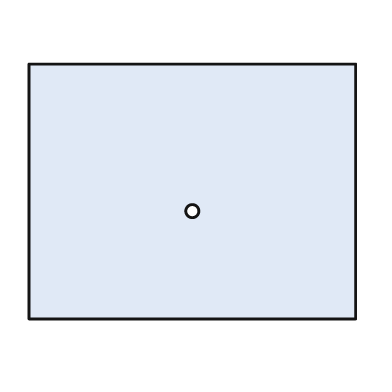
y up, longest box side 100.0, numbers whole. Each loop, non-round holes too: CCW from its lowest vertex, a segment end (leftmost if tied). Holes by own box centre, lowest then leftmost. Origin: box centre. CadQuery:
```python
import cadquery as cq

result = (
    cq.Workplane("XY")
    .moveTo(-50.0, -39.0)
    .lineTo(50.0, -39.0)
    .lineTo(50.0, 39.0)
    .lineTo(-50.0, 39.0)
    .close()
    .moveTo(0.0, -6.0)
    .circle(2.0)
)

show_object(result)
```